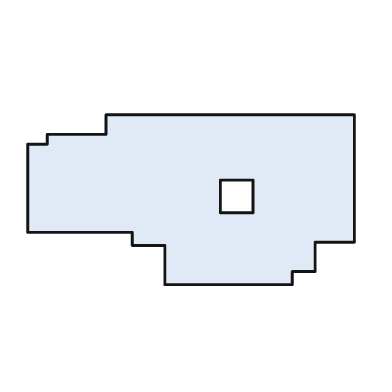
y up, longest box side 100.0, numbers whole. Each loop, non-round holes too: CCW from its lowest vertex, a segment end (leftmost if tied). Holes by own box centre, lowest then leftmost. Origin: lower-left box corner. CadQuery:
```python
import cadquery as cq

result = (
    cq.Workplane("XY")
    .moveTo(42.0, 0.0)
    .lineTo(81.0, 0.0)
    .lineTo(81.0, 4.0)
    .lineTo(88.0, 4.0)
    .lineTo(88.0, 13.0)
    .lineTo(100.0, 13.0)
    .lineTo(100.0, 52.0)
    .lineTo(24.0, 52.0)
    .lineTo(24.0, 46.0)
    .lineTo(6.0, 46.0)
    .lineTo(6.0, 43.0)
    .lineTo(0.0, 43.0)
    .lineTo(0.0, 16.0)
    .lineTo(32.0, 16.0)
    .lineTo(32.0, 12.0)
    .lineTo(42.0, 12.0)
    .close()
    .moveTo(59.0, 22.0)
    .lineTo(69.0, 22.0)
    .lineTo(69.0, 32.0)
    .lineTo(59.0, 32.0)
    .close()
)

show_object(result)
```